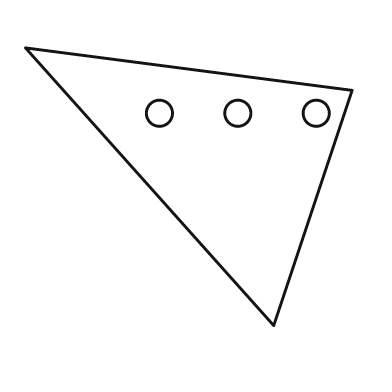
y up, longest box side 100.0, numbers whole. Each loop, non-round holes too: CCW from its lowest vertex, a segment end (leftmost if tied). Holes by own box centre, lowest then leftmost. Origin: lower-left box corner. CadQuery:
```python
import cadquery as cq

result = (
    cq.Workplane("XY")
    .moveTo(76.0, 0.0)
    .lineTo(100.0, 72.0)
    .lineTo(0.0, 85.0)
    .close()
    .moveTo(41.0, 65.0)
    .circle(4.0)
    .moveTo(65.0, 65.0)
    .circle(4.0)
    .moveTo(89.0, 65.0)
    .circle(4.0)
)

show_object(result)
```